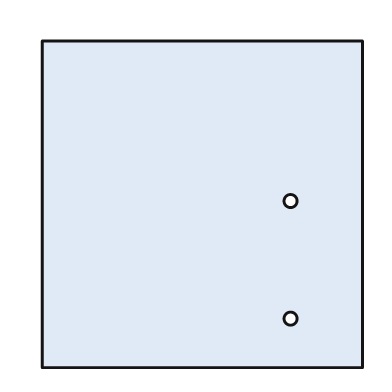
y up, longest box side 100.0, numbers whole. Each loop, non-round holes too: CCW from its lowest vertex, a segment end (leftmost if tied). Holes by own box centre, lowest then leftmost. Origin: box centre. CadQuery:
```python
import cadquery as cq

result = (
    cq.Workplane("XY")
    .moveTo(-49.0, -50.0)
    .lineTo(49.0, -50.0)
    .lineTo(49.0, 50.0)
    .lineTo(-49.0, 50.0)
    .close()
    .moveTo(27.0, -35.0)
    .circle(2.0)
    .moveTo(27.0, 1.0)
    .circle(2.0)
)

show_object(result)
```